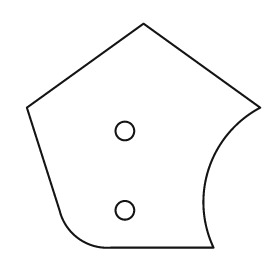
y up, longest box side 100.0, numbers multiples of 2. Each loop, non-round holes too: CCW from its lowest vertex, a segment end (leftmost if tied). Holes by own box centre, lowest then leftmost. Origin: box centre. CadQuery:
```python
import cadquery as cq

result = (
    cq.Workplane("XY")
    .moveTo(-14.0, -48.0)
    .lineTo(30.0, -48.0)
    .threePointArc((28.0, -14.0), (50.0, 12.0))
    .lineTo(0.0, 48.0)
    .lineTo(-50.0, 12.0)
    .lineTo(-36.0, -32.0)
    .threePointArc((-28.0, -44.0), (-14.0, -48.0))
    .close()
    .moveTo(-8.0, -32.0)
    .circle(4.0)
    .moveTo(-8.0, 2.0)
    .circle(4.0)
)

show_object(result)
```